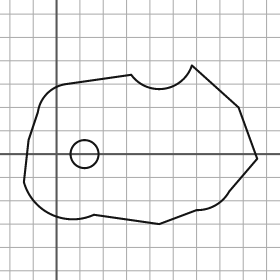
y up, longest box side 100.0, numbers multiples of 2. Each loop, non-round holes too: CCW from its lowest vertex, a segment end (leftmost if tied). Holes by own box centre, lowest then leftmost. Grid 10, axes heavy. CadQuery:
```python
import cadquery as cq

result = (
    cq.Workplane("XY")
    .moveTo(44.0, -30.0)
    .lineTo(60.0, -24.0)
    .threePointArc((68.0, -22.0), (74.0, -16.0))
    .lineTo(86.0, -2.0)
    .lineTo(78.0, 20.0)
    .lineTo(58.0, 38.0)
    .threePointArc((46.0, 28.0), (32.0, 34.0))
    .lineTo(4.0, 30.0)
    .threePointArc((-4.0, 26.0), (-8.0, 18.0))
    .lineTo(-12.0, 6.0)
    .lineTo(-14.0, -12.0)
    .threePointArc((-2.0, -26.0), (16.0, -26.0))
    .close()
    .moveTo(12.0, 0.0)
    .circle(6.0)
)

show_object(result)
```